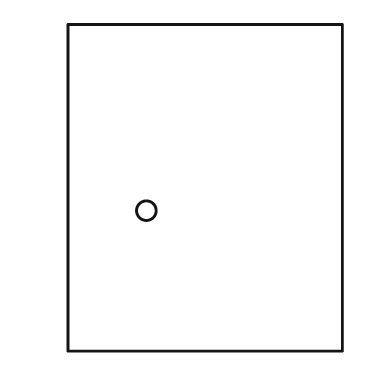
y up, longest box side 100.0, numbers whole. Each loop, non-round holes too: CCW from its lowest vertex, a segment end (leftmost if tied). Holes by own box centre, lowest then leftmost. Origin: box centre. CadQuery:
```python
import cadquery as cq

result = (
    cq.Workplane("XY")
    .moveTo(-42.0, -50.0)
    .lineTo(42.0, -50.0)
    .lineTo(42.0, 50.0)
    .lineTo(-42.0, 50.0)
    .close()
    .moveTo(-18.0, -7.0)
    .circle(3.0)
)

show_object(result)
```